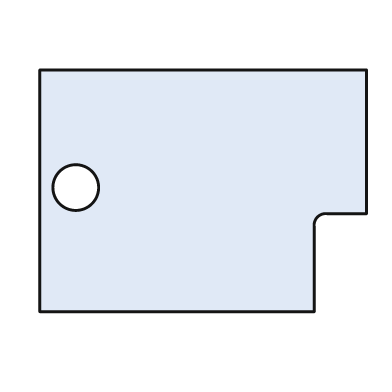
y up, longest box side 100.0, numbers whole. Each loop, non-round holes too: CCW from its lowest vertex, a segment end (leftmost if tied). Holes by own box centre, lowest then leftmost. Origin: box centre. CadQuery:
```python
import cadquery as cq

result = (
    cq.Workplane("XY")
    .moveTo(-50.0, -37.0)
    .lineTo(34.0, -37.0)
    .lineTo(34.0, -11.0)
    .threePointArc((35.0, -8.0), (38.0, -7.0))
    .lineTo(50.0, -7.0)
    .lineTo(50.0, 37.0)
    .lineTo(-50.0, 37.0)
    .close()
    .moveTo(-39.0, 1.0)
    .circle(7.0)
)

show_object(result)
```